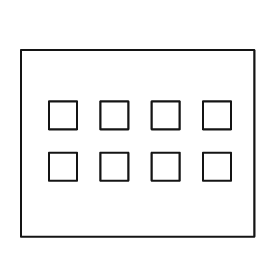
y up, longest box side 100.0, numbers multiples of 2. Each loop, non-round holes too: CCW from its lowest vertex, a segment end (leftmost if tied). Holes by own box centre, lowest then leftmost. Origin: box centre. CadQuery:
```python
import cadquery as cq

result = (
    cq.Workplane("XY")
    .moveTo(-50.0, -40.0)
    .lineTo(50.0, -40.0)
    .lineTo(50.0, 40.0)
    .lineTo(-50.0, 40.0)
    .close()
    .moveTo(-38.0, -16.0)
    .lineTo(-26.0, -16.0)
    .lineTo(-26.0, -4.0)
    .lineTo(-38.0, -4.0)
    .close()
    .moveTo(-16.0, -16.0)
    .lineTo(-4.0, -16.0)
    .lineTo(-4.0, -4.0)
    .lineTo(-16.0, -4.0)
    .close()
    .moveTo(6.0, -16.0)
    .lineTo(18.0, -16.0)
    .lineTo(18.0, -4.0)
    .lineTo(6.0, -4.0)
    .close()
    .moveTo(28.0, -16.0)
    .lineTo(40.0, -16.0)
    .lineTo(40.0, -4.0)
    .lineTo(28.0, -4.0)
    .close()
    .moveTo(-38.0, 6.0)
    .lineTo(-26.0, 6.0)
    .lineTo(-26.0, 18.0)
    .lineTo(-38.0, 18.0)
    .close()
    .moveTo(-16.0, 6.0)
    .lineTo(-4.0, 6.0)
    .lineTo(-4.0, 18.0)
    .lineTo(-16.0, 18.0)
    .close()
    .moveTo(6.0, 6.0)
    .lineTo(18.0, 6.0)
    .lineTo(18.0, 18.0)
    .lineTo(6.0, 18.0)
    .close()
    .moveTo(28.0, 6.0)
    .lineTo(40.0, 6.0)
    .lineTo(40.0, 18.0)
    .lineTo(28.0, 18.0)
    .close()
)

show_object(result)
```